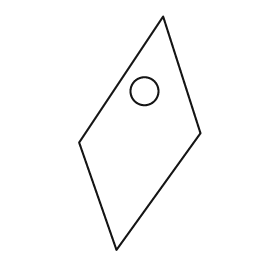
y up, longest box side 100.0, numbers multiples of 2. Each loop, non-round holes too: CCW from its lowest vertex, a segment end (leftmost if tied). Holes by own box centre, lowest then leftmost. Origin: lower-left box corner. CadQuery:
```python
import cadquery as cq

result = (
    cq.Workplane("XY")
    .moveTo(16.0, 0.0)
    .lineTo(52.0, 50.0)
    .lineTo(36.0, 100.0)
    .lineTo(0.0, 46.0)
    .close()
    .moveTo(28.0, 68.0)
    .circle(6.0)
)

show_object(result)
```